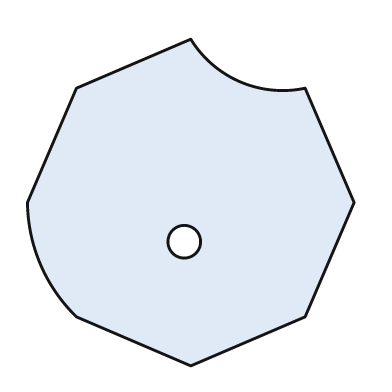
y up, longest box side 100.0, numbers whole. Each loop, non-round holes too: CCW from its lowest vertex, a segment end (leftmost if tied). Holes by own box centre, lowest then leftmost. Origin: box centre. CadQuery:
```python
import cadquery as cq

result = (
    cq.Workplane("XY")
    .moveTo(0.0, -50.0)
    .lineTo(35.0, -35.0)
    .lineTo(50.0, 0.0)
    .lineTo(35.0, 35.0)
    .threePointArc((15.0, 37.0), (0.0, 50.0))
    .lineTo(-35.0, 35.0)
    .lineTo(-50.0, 0.0)
    .threePointArc((-46.0, -19.0), (-35.0, -35.0))
    .close()
    .moveTo(-2.0, -12.0)
    .circle(5.0)
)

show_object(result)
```